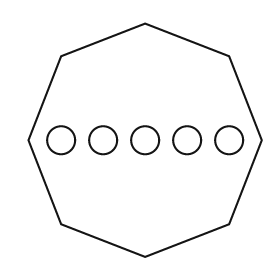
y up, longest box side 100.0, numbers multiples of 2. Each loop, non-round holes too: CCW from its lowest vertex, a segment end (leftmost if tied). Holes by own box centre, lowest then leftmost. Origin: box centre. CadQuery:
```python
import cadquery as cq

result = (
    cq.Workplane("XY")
    .moveTo(0.0, -50.0)
    .lineTo(36.0, -36.0)
    .lineTo(50.0, 0.0)
    .lineTo(36.0, 36.0)
    .lineTo(0.0, 50.0)
    .lineTo(-36.0, 36.0)
    .lineTo(-50.0, 0.0)
    .lineTo(-36.0, -36.0)
    .close()
    .moveTo(-36.0, 0.0)
    .circle(6.0)
    .moveTo(-18.0, 0.0)
    .circle(6.0)
    .moveTo(0.0, 0.0)
    .circle(6.0)
    .moveTo(18.0, 0.0)
    .circle(6.0)
    .moveTo(36.0, 0.0)
    .circle(6.0)
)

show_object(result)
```